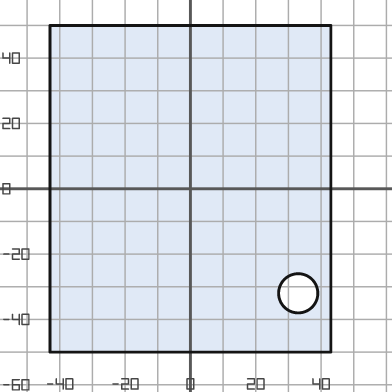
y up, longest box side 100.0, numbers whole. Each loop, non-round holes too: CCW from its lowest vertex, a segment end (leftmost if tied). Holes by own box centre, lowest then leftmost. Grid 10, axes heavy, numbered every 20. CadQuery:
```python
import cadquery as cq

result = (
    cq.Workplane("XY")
    .moveTo(-43.0, -50.0)
    .lineTo(43.0, -50.0)
    .lineTo(43.0, 50.0)
    .lineTo(-43.0, 50.0)
    .close()
    .moveTo(33.0, -32.0)
    .circle(6.0)
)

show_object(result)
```